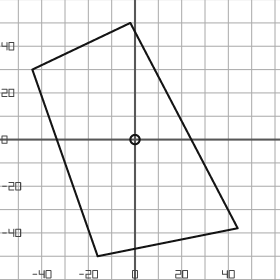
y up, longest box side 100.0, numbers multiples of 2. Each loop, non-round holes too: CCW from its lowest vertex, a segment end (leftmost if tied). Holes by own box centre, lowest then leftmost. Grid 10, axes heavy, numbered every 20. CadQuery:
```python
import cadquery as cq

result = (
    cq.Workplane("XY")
    .moveTo(-16.0, -50.0)
    .lineTo(44.0, -38.0)
    .lineTo(-2.0, 50.0)
    .lineTo(-44.0, 30.0)
    .close()
    .moveTo(0.0, 0.0)
    .circle(2.0)
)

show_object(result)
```